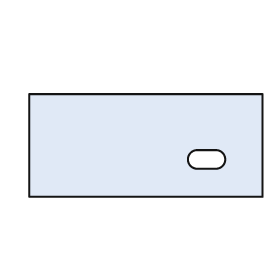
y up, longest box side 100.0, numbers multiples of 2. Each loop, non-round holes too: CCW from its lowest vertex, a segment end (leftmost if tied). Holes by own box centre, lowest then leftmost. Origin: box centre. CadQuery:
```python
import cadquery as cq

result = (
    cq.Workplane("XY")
    .moveTo(-50.0, -22.0)
    .lineTo(50.0, -22.0)
    .lineTo(50.0, 22.0)
    .lineTo(-50.0, 22.0)
    .close()
    .moveTo(22.0, -10.0)
    .lineTo(30.0, -10.0)
    .threePointArc((34.0, -6.0), (30.0, -2.0))
    .lineTo(22.0, -2.0)
    .threePointArc((18.0, -6.0), (22.0, -10.0))
    .close()
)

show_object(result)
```